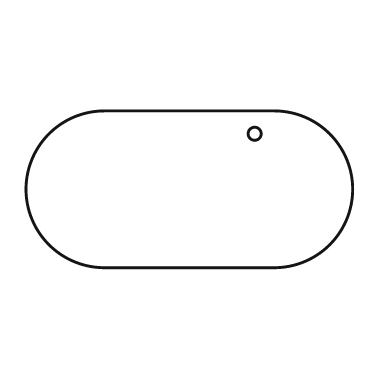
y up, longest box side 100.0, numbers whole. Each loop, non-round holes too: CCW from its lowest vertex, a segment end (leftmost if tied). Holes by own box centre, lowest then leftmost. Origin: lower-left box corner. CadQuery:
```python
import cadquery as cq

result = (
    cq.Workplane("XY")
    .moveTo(24.0, 0.0)
    .lineTo(76.0, 0.0)
    .threePointArc((100.0, 24.0), (76.0, 48.0))
    .lineTo(24.0, 48.0)
    .threePointArc((0.0, 24.0), (24.0, 0.0))
    .close()
    .moveTo(70.0, 41.0)
    .circle(2.0)
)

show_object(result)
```